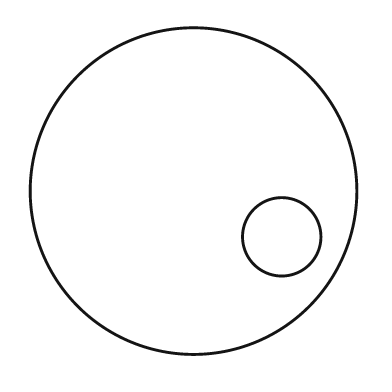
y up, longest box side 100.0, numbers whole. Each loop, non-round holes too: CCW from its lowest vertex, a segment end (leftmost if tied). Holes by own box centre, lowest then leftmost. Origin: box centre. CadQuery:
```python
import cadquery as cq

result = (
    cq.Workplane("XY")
    .moveTo(0.0, 0.0)
    .circle(50.0)
    .moveTo(27.0, -14.0)
    .circle(12.0)
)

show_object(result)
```